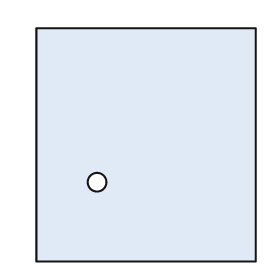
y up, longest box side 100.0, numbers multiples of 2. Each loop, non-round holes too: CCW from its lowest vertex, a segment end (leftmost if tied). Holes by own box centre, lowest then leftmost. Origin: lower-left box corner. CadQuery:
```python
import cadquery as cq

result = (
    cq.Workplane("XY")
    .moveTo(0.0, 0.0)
    .lineTo(94.0, 0.0)
    .lineTo(94.0, 100.0)
    .lineTo(0.0, 100.0)
    .close()
    .moveTo(26.0, 34.0)
    .circle(4.0)
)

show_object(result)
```